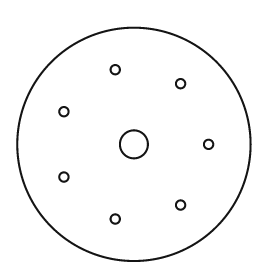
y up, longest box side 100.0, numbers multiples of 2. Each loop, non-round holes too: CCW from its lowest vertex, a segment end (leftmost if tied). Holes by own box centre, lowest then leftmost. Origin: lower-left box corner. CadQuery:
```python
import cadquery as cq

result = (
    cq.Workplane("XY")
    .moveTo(50.0, 50.0)
    .circle(50.0)
    .moveTo(42.0, 18.0)
    .circle(2.0)
    .moveTo(70.0, 24.0)
    .circle(2.0)
    .moveTo(20.0, 36.0)
    .circle(2.0)
    .moveTo(50.0, 50.0)
    .circle(6.0)
    .moveTo(82.0, 50.0)
    .circle(2.0)
    .moveTo(20.0, 64.0)
    .circle(2.0)
    .moveTo(70.0, 76.0)
    .circle(2.0)
    .moveTo(42.0, 82.0)
    .circle(2.0)
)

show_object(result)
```